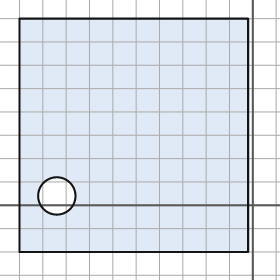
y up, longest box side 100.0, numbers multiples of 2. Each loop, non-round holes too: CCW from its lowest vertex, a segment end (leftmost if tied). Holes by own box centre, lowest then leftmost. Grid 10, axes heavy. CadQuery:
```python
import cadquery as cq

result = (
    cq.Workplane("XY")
    .moveTo(-100.0, -20.0)
    .lineTo(-2.0, -20.0)
    .lineTo(-2.0, 80.0)
    .lineTo(-100.0, 80.0)
    .close()
    .moveTo(-84.0, 4.0)
    .circle(8.0)
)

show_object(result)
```